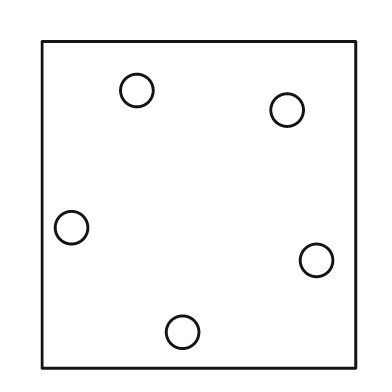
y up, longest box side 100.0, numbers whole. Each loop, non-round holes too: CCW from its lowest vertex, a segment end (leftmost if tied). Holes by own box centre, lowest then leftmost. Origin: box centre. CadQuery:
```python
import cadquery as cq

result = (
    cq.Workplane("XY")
    .moveTo(-48.0, -50.0)
    .lineTo(48.0, -50.0)
    .lineTo(48.0, 50.0)
    .lineTo(-48.0, 50.0)
    .close()
    .moveTo(-5.0, -39.0)
    .circle(5.0)
    .moveTo(36.0, -17.0)
    .circle(5.0)
    .moveTo(-39.0, -7.0)
    .circle(5.0)
    .moveTo(27.0, 29.0)
    .circle(5.0)
    .moveTo(-19.0, 35.0)
    .circle(5.0)
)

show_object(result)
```